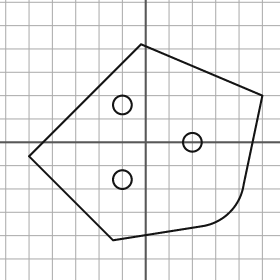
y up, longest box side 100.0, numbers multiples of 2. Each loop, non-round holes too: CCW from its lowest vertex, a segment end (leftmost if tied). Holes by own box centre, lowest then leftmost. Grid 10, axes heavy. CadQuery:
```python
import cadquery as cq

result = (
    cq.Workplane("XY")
    .moveTo(-14.0, -42.0)
    .lineTo(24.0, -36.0)
    .threePointArc((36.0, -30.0), (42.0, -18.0))
    .lineTo(50.0, 20.0)
    .lineTo(-2.0, 42.0)
    .lineTo(-50.0, -6.0)
    .close()
    .moveTo(-10.0, -16.0)
    .circle(4.0)
    .moveTo(20.0, 0.0)
    .circle(4.0)
    .moveTo(-10.0, 16.0)
    .circle(4.0)
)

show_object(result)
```